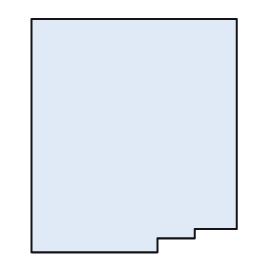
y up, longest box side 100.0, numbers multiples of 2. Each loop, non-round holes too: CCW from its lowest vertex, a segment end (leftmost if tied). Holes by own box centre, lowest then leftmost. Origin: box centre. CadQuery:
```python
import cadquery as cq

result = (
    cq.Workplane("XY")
    .moveTo(-44.0, -50.0)
    .lineTo(10.0, -50.0)
    .lineTo(10.0, -44.0)
    .lineTo(26.0, -44.0)
    .lineTo(26.0, -40.0)
    .lineTo(44.0, -40.0)
    .lineTo(44.0, 50.0)
    .lineTo(-44.0, 50.0)
    .close()
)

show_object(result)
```